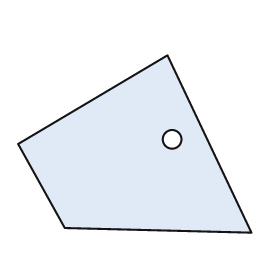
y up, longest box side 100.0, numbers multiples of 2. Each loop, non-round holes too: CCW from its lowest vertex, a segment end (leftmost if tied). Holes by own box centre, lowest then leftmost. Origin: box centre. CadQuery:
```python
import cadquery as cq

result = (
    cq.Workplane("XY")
    .moveTo(50.0, -38.0)
    .lineTo(14.0, 38.0)
    .lineTo(-50.0, 0.0)
    .lineTo(-30.0, -36.0)
    .close()
    .moveTo(16.0, 2.0)
    .circle(4.0)
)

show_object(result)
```